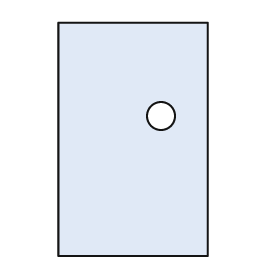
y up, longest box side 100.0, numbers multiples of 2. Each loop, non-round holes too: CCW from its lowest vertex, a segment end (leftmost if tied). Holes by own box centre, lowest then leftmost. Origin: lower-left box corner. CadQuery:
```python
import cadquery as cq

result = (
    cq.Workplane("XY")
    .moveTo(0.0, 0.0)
    .lineTo(64.0, 0.0)
    .lineTo(64.0, 100.0)
    .lineTo(0.0, 100.0)
    .close()
    .moveTo(44.0, 60.0)
    .circle(6.0)
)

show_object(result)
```